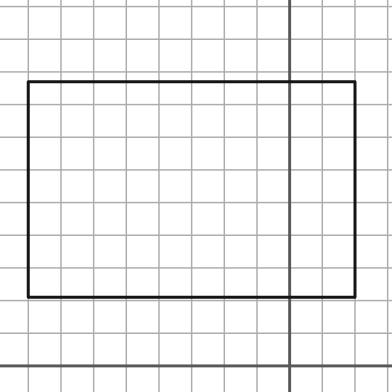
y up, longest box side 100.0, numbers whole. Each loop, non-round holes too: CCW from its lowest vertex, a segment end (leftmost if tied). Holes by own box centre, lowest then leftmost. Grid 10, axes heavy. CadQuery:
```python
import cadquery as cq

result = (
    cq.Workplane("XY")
    .moveTo(-80.0, 21.0)
    .lineTo(20.0, 21.0)
    .lineTo(20.0, 87.0)
    .lineTo(-80.0, 87.0)
    .close()
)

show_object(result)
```